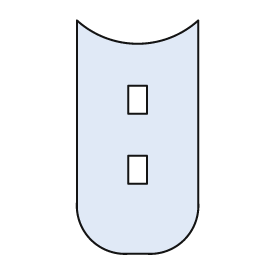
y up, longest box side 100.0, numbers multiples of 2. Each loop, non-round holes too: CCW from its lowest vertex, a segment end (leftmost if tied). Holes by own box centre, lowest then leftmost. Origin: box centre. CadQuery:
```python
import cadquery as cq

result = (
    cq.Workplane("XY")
    .moveTo(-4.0, -50.0)
    .lineTo(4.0, -50.0)
    .threePointArc((20.0, -44.0), (26.0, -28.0))
    .lineTo(26.0, 50.0)
    .threePointArc((0.0, 40.0), (-26.0, 50.0))
    .lineTo(-26.0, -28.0)
    .threePointArc((-20.0, -44.0), (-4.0, -50.0))
    .close()
    .moveTo(-4.0, -20.0)
    .lineTo(4.0, -20.0)
    .lineTo(4.0, -8.0)
    .lineTo(-4.0, -8.0)
    .close()
    .moveTo(-4.0, 10.0)
    .lineTo(4.0, 10.0)
    .lineTo(4.0, 22.0)
    .lineTo(-4.0, 22.0)
    .close()
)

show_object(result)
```